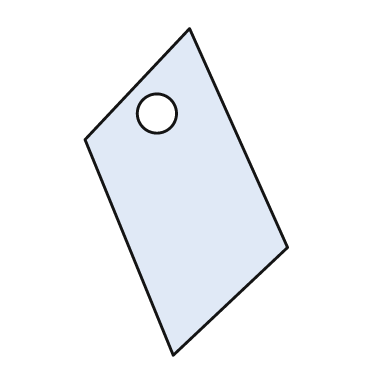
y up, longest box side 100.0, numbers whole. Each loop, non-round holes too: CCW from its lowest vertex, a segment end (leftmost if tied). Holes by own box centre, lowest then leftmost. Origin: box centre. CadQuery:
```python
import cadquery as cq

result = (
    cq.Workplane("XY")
    .moveTo(-4.0, -50.0)
    .lineTo(31.0, -17.0)
    .lineTo(1.0, 50.0)
    .lineTo(-31.0, 16.0)
    .close()
    .moveTo(-9.0, 24.0)
    .circle(6.0)
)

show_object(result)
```